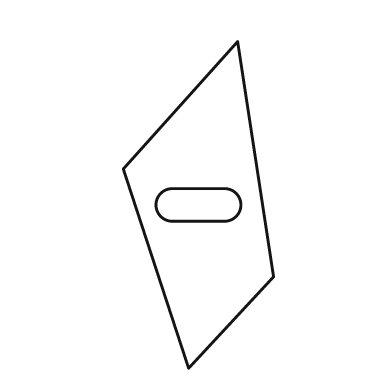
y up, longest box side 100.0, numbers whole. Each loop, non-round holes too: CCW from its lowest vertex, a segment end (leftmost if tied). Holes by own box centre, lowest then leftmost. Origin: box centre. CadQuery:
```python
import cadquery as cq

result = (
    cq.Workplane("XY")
    .moveTo(-3.0, -50.0)
    .lineTo(23.0, -22.0)
    .lineTo(12.0, 50.0)
    .lineTo(-23.0, 11.0)
    .close()
    .moveTo(-8.0, -5.0)
    .lineTo(8.0, -5.0)
    .threePointArc((13.0, 0.0), (8.0, 5.0))
    .lineTo(-8.0, 5.0)
    .threePointArc((-13.0, 0.0), (-8.0, -5.0))
    .close()
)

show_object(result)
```